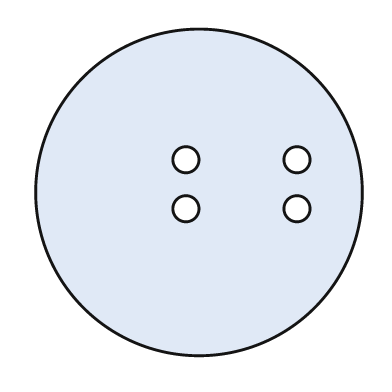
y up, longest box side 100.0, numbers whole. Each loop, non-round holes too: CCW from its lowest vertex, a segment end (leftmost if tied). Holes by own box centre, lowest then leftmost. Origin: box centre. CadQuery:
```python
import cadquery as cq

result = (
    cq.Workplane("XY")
    .moveTo(0.0, 0.0)
    .circle(50.0)
    .moveTo(-4.0, -5.0)
    .circle(4.0)
    .moveTo(30.0, -5.0)
    .circle(4.0)
    .moveTo(-4.0, 10.0)
    .circle(4.0)
    .moveTo(30.0, 10.0)
    .circle(4.0)
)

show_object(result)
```